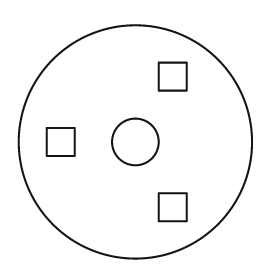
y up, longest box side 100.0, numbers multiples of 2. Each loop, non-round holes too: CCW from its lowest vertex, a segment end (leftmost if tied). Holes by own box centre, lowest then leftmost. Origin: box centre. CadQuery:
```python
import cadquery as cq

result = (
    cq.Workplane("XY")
    .moveTo(0.0, 0.0)
    .circle(50.0)
    .moveTo(10.0, -34.0)
    .lineTo(22.0, -34.0)
    .lineTo(22.0, -22.0)
    .lineTo(10.0, -22.0)
    .close()
    .moveTo(-38.0, -6.0)
    .lineTo(-26.0, -6.0)
    .lineTo(-26.0, 6.0)
    .lineTo(-38.0, 6.0)
    .close()
    .moveTo(0.0, 0.0)
    .circle(10.0)
    .moveTo(10.0, 22.0)
    .lineTo(22.0, 22.0)
    .lineTo(22.0, 34.0)
    .lineTo(10.0, 34.0)
    .close()
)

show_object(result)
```